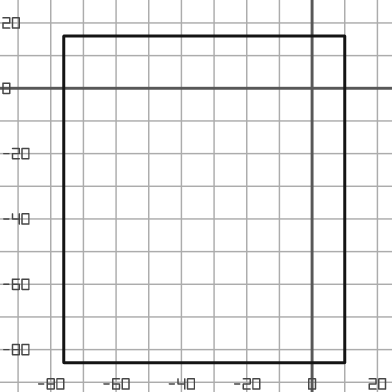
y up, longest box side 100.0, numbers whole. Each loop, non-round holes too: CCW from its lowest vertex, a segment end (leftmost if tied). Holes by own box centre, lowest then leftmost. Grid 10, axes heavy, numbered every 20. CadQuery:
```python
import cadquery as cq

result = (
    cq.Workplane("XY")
    .moveTo(-76.0, -84.0)
    .lineTo(10.0, -84.0)
    .lineTo(10.0, 16.0)
    .lineTo(-76.0, 16.0)
    .close()
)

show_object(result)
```